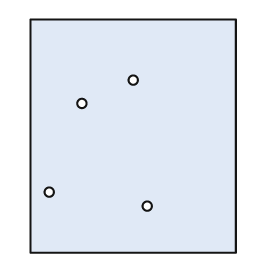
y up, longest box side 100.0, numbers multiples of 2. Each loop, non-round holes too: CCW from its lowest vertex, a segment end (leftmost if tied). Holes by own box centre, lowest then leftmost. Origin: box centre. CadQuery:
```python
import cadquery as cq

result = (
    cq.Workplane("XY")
    .moveTo(-44.0, -50.0)
    .lineTo(44.0, -50.0)
    .lineTo(44.0, 50.0)
    .lineTo(-44.0, 50.0)
    .close()
    .moveTo(6.0, -30.0)
    .circle(2.0)
    .moveTo(-36.0, -24.0)
    .circle(2.0)
    .moveTo(-22.0, 14.0)
    .circle(2.0)
    .moveTo(0.0, 24.0)
    .circle(2.0)
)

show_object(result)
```